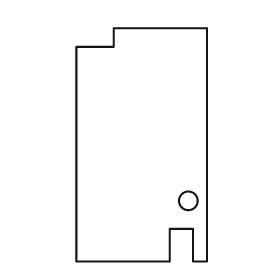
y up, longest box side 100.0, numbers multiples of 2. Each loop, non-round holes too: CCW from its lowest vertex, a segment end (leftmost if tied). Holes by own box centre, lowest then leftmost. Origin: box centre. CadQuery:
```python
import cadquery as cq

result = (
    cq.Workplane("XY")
    .moveTo(-28.0, -50.0)
    .lineTo(12.0, -50.0)
    .lineTo(12.0, -36.0)
    .lineTo(22.0, -36.0)
    .lineTo(22.0, -50.0)
    .lineTo(28.0, -50.0)
    .lineTo(28.0, 50.0)
    .lineTo(-12.0, 50.0)
    .lineTo(-12.0, 42.0)
    .lineTo(-28.0, 42.0)
    .close()
    .moveTo(20.0, -24.0)
    .circle(4.0)
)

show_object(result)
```